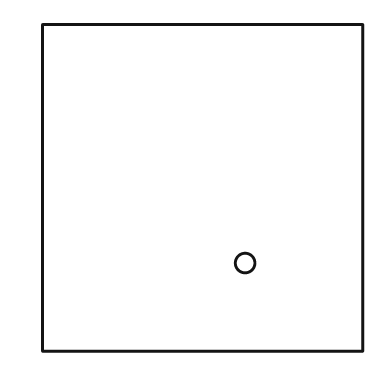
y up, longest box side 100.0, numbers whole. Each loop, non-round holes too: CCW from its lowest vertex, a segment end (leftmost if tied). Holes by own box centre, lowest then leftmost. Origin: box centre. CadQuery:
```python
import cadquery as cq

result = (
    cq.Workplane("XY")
    .moveTo(-49.0, -50.0)
    .lineTo(49.0, -50.0)
    .lineTo(49.0, 50.0)
    .lineTo(-49.0, 50.0)
    .close()
    .moveTo(13.0, -23.0)
    .circle(3.0)
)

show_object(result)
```